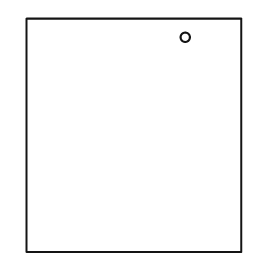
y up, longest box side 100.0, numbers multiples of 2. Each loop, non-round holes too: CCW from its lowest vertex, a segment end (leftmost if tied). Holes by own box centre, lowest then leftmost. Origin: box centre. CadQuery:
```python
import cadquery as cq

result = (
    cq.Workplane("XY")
    .moveTo(-46.0, -50.0)
    .lineTo(46.0, -50.0)
    .lineTo(46.0, 50.0)
    .lineTo(-46.0, 50.0)
    .close()
    .moveTo(22.0, 42.0)
    .circle(2.0)
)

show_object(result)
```